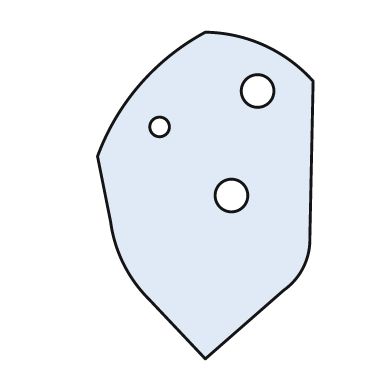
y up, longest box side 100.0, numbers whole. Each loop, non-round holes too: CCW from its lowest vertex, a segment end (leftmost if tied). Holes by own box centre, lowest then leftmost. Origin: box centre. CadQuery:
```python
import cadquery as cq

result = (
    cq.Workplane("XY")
    .moveTo(0.0, -50.0)
    .lineTo(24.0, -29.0)
    .threePointArc((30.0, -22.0), (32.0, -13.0))
    .lineTo(33.0, 35.0)
    .threePointArc((18.0, 46.0), (0.0, 50.0))
    .threePointArc((-20.0, 34.0), (-33.0, 12.0))
    .lineTo(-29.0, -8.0)
    .threePointArc((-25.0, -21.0), (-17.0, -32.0))
    .close()
    .moveTo(8.0, 0.0)
    .circle(5.0)
    .moveTo(-14.0, 21.0)
    .circle(3.0)
    .moveTo(16.0, 32.0)
    .circle(5.0)
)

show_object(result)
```